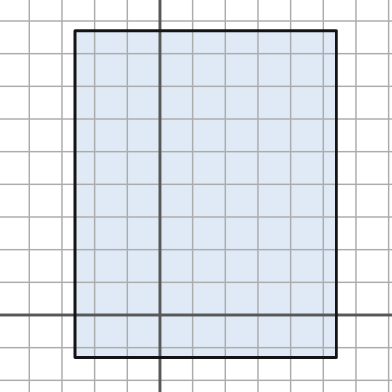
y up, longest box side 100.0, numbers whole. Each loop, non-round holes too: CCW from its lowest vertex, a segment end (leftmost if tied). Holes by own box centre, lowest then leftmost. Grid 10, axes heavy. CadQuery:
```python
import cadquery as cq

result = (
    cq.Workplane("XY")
    .moveTo(-26.0, -13.0)
    .lineTo(54.0, -13.0)
    .lineTo(54.0, 87.0)
    .lineTo(-26.0, 87.0)
    .close()
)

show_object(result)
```